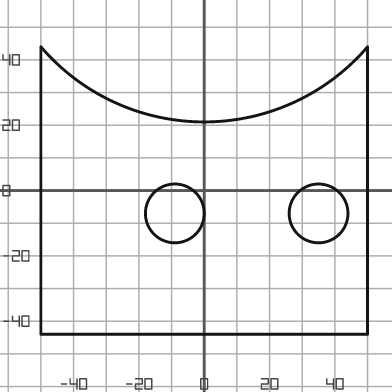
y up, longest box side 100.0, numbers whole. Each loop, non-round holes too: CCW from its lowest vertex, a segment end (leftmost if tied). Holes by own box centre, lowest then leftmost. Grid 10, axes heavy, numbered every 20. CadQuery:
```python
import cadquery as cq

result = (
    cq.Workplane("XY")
    .moveTo(-50.0, -44.0)
    .lineTo(50.0, -44.0)
    .lineTo(50.0, 44.0)
    .threePointArc((0.0, 21.0), (-50.0, 44.0))
    .close()
    .moveTo(-9.0, -7.0)
    .circle(9.0)
    .moveTo(35.0, -7.0)
    .circle(9.0)
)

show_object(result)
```